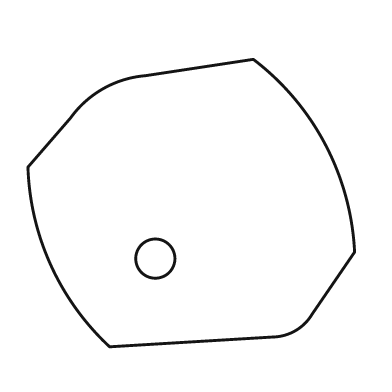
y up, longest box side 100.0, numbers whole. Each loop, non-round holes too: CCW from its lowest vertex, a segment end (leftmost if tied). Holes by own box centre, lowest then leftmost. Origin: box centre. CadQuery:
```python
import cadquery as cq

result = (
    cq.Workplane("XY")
    .moveTo(-25.0, -44.0)
    .lineTo(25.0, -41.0)
    .threePointArc((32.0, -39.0), (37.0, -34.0))
    .lineTo(50.0, -15.0)
    .threePointArc((41.0, 18.0), (19.0, 44.0))
    .lineTo(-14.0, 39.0)
    .threePointArc((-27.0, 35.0), (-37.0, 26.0))
    .lineTo(-50.0, 11.0)
    .threePointArc((-43.0, -19.0), (-25.0, -44.0))
    .close()
    .moveTo(-11.0, -17.0)
    .circle(6.0)
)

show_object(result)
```